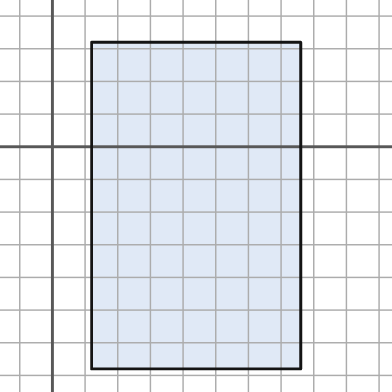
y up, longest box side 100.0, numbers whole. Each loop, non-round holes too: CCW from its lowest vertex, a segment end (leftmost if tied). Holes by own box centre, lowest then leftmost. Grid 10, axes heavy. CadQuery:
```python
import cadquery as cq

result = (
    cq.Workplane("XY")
    .moveTo(12.0, -68.0)
    .lineTo(76.0, -68.0)
    .lineTo(76.0, 32.0)
    .lineTo(12.0, 32.0)
    .close()
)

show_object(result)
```